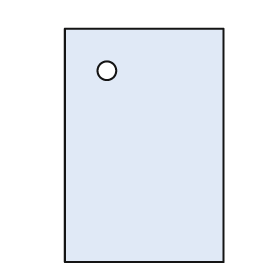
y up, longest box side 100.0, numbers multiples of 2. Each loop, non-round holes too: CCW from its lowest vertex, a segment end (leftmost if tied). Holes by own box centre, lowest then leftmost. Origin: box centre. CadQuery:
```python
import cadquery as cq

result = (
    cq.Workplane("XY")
    .moveTo(-34.0, -50.0)
    .lineTo(34.0, -50.0)
    .lineTo(34.0, 50.0)
    .lineTo(-34.0, 50.0)
    .close()
    .moveTo(-16.0, 32.0)
    .circle(4.0)
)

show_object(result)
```